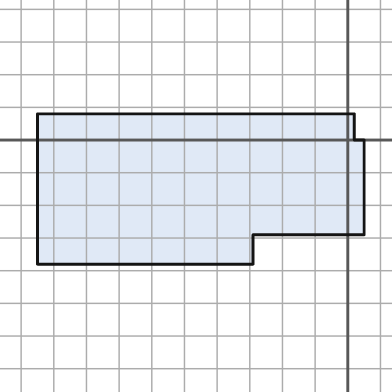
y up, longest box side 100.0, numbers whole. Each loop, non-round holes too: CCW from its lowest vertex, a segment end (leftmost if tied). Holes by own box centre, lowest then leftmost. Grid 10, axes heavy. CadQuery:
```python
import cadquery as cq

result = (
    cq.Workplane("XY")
    .moveTo(-95.0, -38.0)
    .lineTo(-29.0, -38.0)
    .lineTo(-29.0, -29.0)
    .lineTo(5.0, -29.0)
    .lineTo(5.0, 0.0)
    .lineTo(2.0, 0.0)
    .lineTo(2.0, 8.0)
    .lineTo(-95.0, 8.0)
    .close()
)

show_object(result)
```